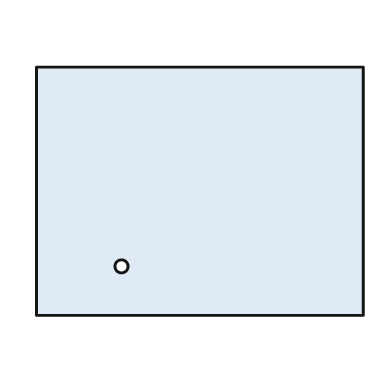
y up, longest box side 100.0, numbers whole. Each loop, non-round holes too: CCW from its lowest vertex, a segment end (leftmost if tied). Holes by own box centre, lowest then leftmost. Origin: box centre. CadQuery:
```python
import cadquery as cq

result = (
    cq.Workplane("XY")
    .moveTo(-50.0, -38.0)
    .lineTo(50.0, -38.0)
    .lineTo(50.0, 38.0)
    .lineTo(-50.0, 38.0)
    .close()
    .moveTo(-24.0, -23.0)
    .circle(2.0)
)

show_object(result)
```